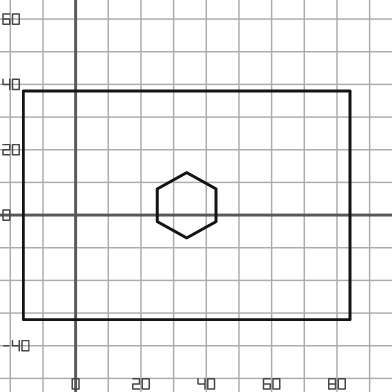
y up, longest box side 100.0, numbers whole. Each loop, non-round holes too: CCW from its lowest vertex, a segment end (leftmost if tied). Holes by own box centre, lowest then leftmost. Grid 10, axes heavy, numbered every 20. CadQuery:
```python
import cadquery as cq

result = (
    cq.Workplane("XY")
    .moveTo(-16.0, -32.0)
    .lineTo(84.0, -32.0)
    .lineTo(84.0, 38.0)
    .lineTo(-16.0, 38.0)
    .close()
    .moveTo(34.0, -7.0)
    .lineTo(43.0, -2.0)
    .lineTo(43.0, 8.0)
    .lineTo(34.0, 13.0)
    .lineTo(25.0, 8.0)
    .lineTo(25.0, -2.0)
    .close()
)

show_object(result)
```